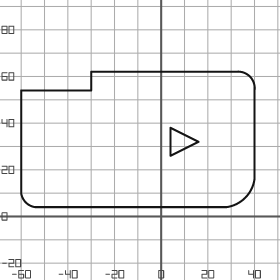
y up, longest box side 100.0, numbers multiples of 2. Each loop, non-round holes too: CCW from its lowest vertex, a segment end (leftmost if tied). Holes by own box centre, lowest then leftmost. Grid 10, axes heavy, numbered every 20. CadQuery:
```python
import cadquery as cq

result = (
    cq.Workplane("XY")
    .moveTo(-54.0, 4.0)
    .lineTo(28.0, 4.0)
    .threePointArc((36.0, 8.0), (40.0, 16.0))
    .lineTo(40.0, 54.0)
    .threePointArc((38.0, 60.0), (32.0, 62.0))
    .lineTo(-30.0, 62.0)
    .lineTo(-30.0, 54.0)
    .lineTo(-60.0, 54.0)
    .lineTo(-60.0, 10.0)
    .threePointArc((-58.0, 6.0), (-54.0, 4.0))
    .close()
    .moveTo(4.0, 26.0)
    .lineTo(16.0, 32.0)
    .lineTo(4.0, 38.0)
    .close()
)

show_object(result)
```